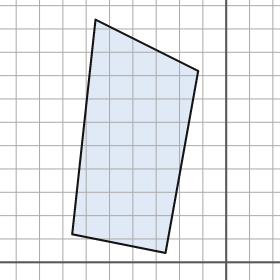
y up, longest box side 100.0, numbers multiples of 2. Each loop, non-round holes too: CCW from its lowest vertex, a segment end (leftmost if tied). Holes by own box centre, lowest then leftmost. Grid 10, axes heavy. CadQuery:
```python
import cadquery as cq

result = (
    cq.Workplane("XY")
    .moveTo(-26.0, 4.0)
    .lineTo(-12.0, 82.0)
    .lineTo(-56.0, 104.0)
    .lineTo(-66.0, 12.0)
    .close()
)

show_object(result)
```